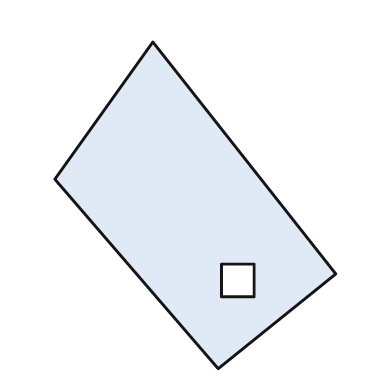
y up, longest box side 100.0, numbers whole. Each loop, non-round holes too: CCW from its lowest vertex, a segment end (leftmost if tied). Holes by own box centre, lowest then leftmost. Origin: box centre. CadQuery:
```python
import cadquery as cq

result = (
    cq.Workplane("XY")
    .moveTo(7.0, -50.0)
    .lineTo(43.0, -21.0)
    .lineTo(-13.0, 50.0)
    .lineTo(-43.0, 8.0)
    .close()
    .moveTo(8.0, -28.0)
    .lineTo(18.0, -28.0)
    .lineTo(18.0, -18.0)
    .lineTo(8.0, -18.0)
    .close()
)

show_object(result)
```